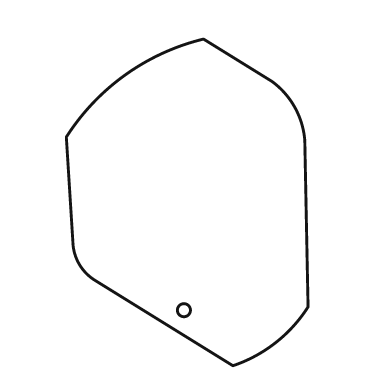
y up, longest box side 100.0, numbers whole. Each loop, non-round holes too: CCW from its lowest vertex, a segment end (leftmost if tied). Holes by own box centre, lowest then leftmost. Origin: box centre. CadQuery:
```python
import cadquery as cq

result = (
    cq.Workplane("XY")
    .moveTo(14.0, -50.0)
    .threePointArc((27.0, -43.0), (37.0, -32.0))
    .lineTo(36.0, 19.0)
    .threePointArc((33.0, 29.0), (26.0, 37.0))
    .lineTo(5.0, 50.0)
    .threePointArc((-19.0, 39.0), (-37.0, 20.0))
    .lineTo(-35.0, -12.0)
    .threePointArc((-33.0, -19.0), (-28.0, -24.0))
    .close()
    .moveTo(-1.0, -33.0)
    .circle(2.0)
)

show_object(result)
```